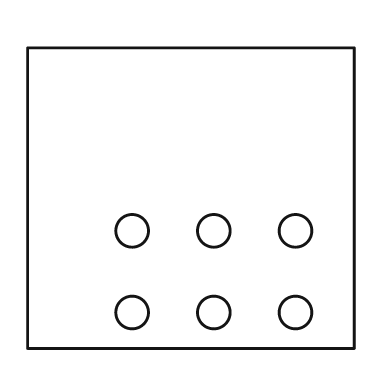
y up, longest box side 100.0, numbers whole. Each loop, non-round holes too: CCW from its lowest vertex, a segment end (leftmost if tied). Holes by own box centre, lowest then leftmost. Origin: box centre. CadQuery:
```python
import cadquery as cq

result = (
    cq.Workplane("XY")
    .moveTo(-50.0, -46.0)
    .lineTo(50.0, -46.0)
    .lineTo(50.0, 46.0)
    .lineTo(-50.0, 46.0)
    .close()
    .moveTo(-18.0, -35.0)
    .circle(5.0)
    .moveTo(7.0, -35.0)
    .circle(5.0)
    .moveTo(32.0, -35.0)
    .circle(5.0)
    .moveTo(-18.0, -10.0)
    .circle(5.0)
    .moveTo(7.0, -10.0)
    .circle(5.0)
    .moveTo(32.0, -10.0)
    .circle(5.0)
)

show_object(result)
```